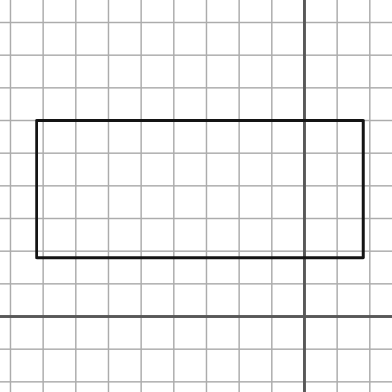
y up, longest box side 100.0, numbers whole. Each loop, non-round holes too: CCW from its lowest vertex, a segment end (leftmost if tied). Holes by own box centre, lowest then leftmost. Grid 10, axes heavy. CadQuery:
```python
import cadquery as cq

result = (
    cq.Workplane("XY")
    .moveTo(-82.0, 18.0)
    .lineTo(18.0, 18.0)
    .lineTo(18.0, 60.0)
    .lineTo(-82.0, 60.0)
    .close()
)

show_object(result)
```